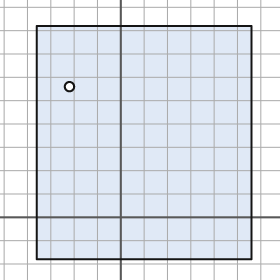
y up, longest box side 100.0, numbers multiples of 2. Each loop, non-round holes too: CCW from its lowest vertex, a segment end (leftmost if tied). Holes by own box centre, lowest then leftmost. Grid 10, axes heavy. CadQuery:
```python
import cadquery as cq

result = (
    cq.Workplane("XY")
    .moveTo(-36.0, -18.0)
    .lineTo(56.0, -18.0)
    .lineTo(56.0, 82.0)
    .lineTo(-36.0, 82.0)
    .close()
    .moveTo(-22.0, 56.0)
    .circle(2.0)
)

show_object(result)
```